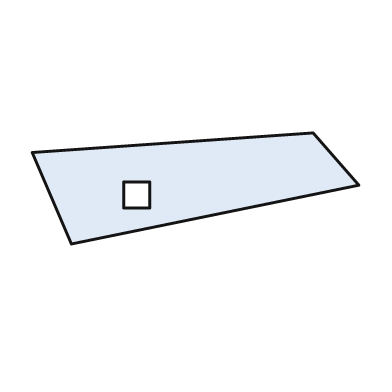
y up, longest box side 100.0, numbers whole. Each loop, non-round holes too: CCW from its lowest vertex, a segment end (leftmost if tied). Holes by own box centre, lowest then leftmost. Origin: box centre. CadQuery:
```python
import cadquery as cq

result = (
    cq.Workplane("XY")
    .moveTo(-38.0, -17.0)
    .lineTo(50.0, 1.0)
    .lineTo(36.0, 17.0)
    .lineTo(-50.0, 11.0)
    .close()
    .moveTo(-22.0, -6.0)
    .lineTo(-14.0, -6.0)
    .lineTo(-14.0, 2.0)
    .lineTo(-22.0, 2.0)
    .close()
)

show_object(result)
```